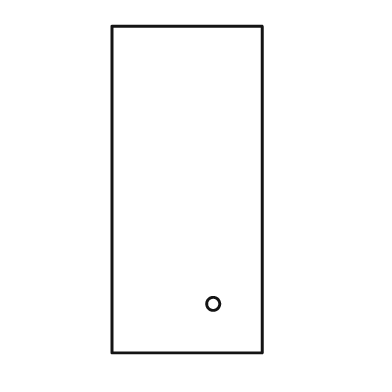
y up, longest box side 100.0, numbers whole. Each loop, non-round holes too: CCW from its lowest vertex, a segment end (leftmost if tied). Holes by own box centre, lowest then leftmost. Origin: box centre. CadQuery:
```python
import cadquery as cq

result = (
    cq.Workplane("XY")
    .moveTo(-23.0, -50.0)
    .lineTo(23.0, -50.0)
    .lineTo(23.0, 50.0)
    .lineTo(-23.0, 50.0)
    .close()
    .moveTo(8.0, -35.0)
    .circle(2.0)
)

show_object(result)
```